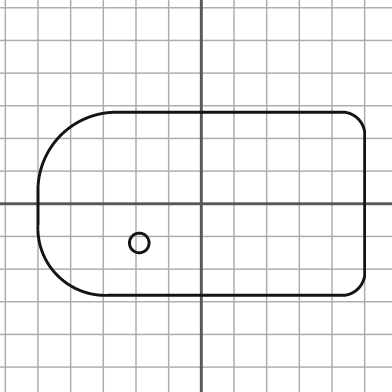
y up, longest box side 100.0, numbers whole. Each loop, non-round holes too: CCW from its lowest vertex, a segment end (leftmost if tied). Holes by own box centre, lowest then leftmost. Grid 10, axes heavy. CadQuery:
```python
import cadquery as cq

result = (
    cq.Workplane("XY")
    .moveTo(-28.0, -28.0)
    .lineTo(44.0, -28.0)
    .threePointArc((48.0, -26.0), (50.0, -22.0))
    .lineTo(50.0, 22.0)
    .threePointArc((48.0, 26.0), (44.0, 28.0))
    .lineTo(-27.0, 28.0)
    .threePointArc((-43.0, 21.0), (-50.0, 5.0))
    .lineTo(-50.0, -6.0)
    .threePointArc((-44.0, -22.0), (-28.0, -28.0))
    .close()
    .moveTo(-19.0, -12.0)
    .circle(3.0)
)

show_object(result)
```